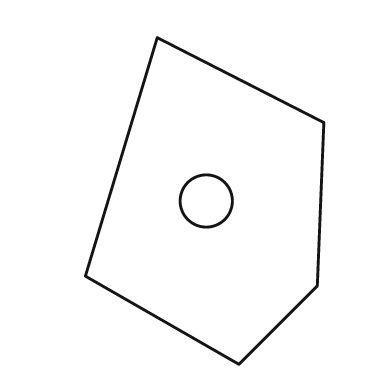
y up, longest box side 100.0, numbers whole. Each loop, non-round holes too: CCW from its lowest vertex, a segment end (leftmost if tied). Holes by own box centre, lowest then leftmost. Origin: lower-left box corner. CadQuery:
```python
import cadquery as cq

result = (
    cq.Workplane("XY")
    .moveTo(47.0, 0.0)
    .lineTo(71.0, 24.0)
    .lineTo(73.0, 74.0)
    .lineTo(22.0, 100.0)
    .lineTo(0.0, 27.0)
    .close()
    .moveTo(37.0, 50.0)
    .circle(8.0)
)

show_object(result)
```